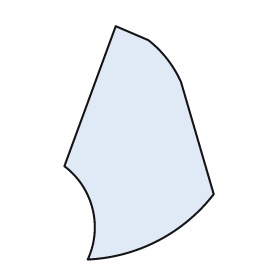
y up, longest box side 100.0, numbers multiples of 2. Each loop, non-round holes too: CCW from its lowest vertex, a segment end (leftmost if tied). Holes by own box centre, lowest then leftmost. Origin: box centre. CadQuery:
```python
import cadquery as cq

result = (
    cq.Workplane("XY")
    .moveTo(-22.0, -50.0)
    .threePointArc((8.0, -42.0), (32.0, -22.0))
    .lineTo(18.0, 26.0)
    .threePointArc((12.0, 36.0), (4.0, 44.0))
    .lineTo(-10.0, 50.0)
    .lineTo(-32.0, -10.0)
    .threePointArc((-20.0, -28.0), (-22.0, -50.0))
    .close()
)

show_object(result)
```